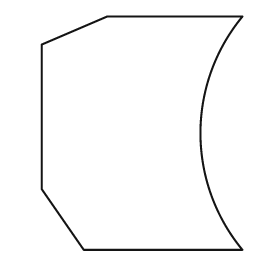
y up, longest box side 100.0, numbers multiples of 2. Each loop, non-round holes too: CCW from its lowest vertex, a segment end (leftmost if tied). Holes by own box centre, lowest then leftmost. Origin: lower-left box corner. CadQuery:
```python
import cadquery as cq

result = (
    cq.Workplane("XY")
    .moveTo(18.0, 0.0)
    .lineTo(86.0, 0.0)
    .threePointArc((68.0, 50.0), (86.0, 100.0))
    .lineTo(28.0, 100.0)
    .lineTo(0.0, 88.0)
    .lineTo(0.0, 26.0)
    .close()
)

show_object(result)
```